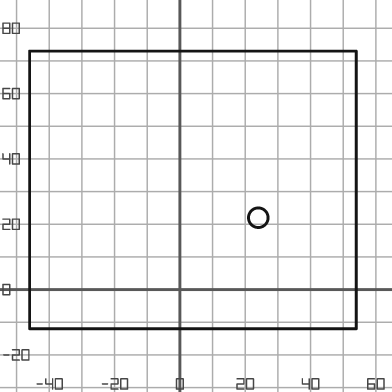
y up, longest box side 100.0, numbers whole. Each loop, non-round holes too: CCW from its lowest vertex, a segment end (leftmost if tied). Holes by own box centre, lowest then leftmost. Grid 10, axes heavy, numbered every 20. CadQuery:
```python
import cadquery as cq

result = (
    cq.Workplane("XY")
    .moveTo(-46.0, -12.0)
    .lineTo(54.0, -12.0)
    .lineTo(54.0, 73.0)
    .lineTo(-46.0, 73.0)
    .close()
    .moveTo(24.0, 22.0)
    .circle(3.0)
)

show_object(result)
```